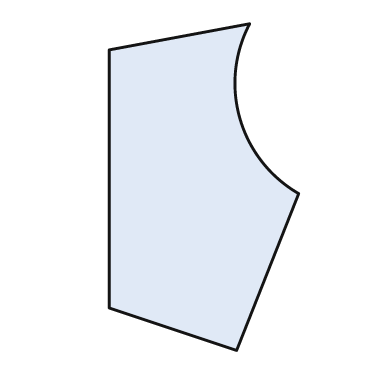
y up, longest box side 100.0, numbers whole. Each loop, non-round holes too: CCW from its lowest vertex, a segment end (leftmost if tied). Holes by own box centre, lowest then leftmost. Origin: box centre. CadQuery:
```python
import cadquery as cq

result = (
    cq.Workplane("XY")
    .moveTo(10.0, -50.0)
    .lineTo(29.0, -2.0)
    .threePointArc((11.0, 21.0), (14.0, 50.0))
    .lineTo(-29.0, 42.0)
    .lineTo(-29.0, -37.0)
    .close()
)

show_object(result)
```